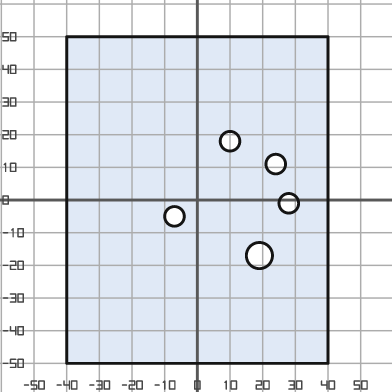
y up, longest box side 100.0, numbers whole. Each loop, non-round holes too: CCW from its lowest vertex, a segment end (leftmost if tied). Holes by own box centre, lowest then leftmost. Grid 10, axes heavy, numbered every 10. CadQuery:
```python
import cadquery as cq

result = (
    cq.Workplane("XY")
    .moveTo(-40.0, -50.0)
    .lineTo(40.0, -50.0)
    .lineTo(40.0, 50.0)
    .lineTo(-40.0, 50.0)
    .close()
    .moveTo(19.0, -17.0)
    .circle(4.0)
    .moveTo(-7.0, -5.0)
    .circle(3.0)
    .moveTo(28.0, -1.0)
    .circle(3.0)
    .moveTo(24.0, 11.0)
    .circle(3.0)
    .moveTo(10.0, 18.0)
    .circle(3.0)
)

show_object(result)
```